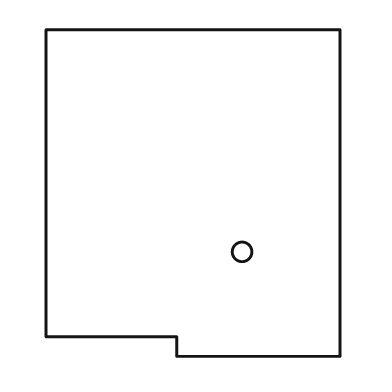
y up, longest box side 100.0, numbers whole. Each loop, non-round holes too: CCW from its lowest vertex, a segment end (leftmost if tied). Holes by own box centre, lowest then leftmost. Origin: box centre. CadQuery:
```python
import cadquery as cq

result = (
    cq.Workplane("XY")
    .moveTo(-5.0, -50.0)
    .lineTo(45.0, -50.0)
    .lineTo(45.0, 50.0)
    .lineTo(-45.0, 50.0)
    .lineTo(-45.0, -44.0)
    .lineTo(-5.0, -44.0)
    .close()
    .moveTo(15.0, -18.0)
    .circle(3.0)
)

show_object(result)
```